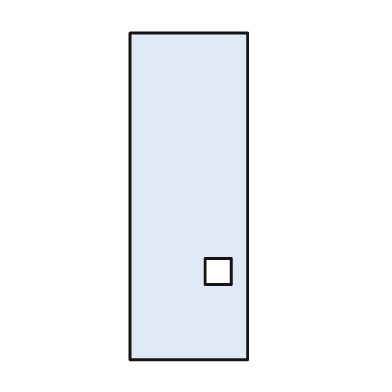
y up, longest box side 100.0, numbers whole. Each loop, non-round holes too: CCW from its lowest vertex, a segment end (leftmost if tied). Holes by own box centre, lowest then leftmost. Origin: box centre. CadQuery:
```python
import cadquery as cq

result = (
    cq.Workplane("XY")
    .moveTo(-18.0, -50.0)
    .lineTo(18.0, -50.0)
    .lineTo(18.0, 50.0)
    .lineTo(-18.0, 50.0)
    .close()
    .moveTo(5.0, -27.0)
    .lineTo(13.0, -27.0)
    .lineTo(13.0, -19.0)
    .lineTo(5.0, -19.0)
    .close()
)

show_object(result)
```